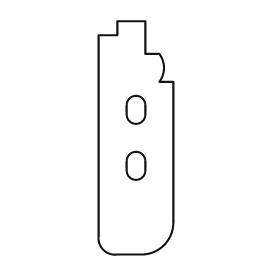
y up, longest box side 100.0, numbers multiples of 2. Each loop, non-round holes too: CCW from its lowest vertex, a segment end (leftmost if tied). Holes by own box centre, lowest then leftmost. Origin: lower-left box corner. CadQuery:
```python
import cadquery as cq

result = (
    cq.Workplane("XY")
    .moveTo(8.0, 0.0)
    .lineTo(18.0, 0.0)
    .threePointArc((28.0, 4.0), (32.0, 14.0))
    .lineTo(32.0, 74.0)
    .lineTo(26.0, 74.0)
    .threePointArc((28.0, 80.0), (26.0, 86.0))
    .lineTo(20.0, 86.0)
    .lineTo(20.0, 100.0)
    .lineTo(8.0, 100.0)
    .lineTo(8.0, 94.0)
    .lineTo(0.0, 94.0)
    .lineTo(0.0, 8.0)
    .threePointArc((2.0, 2.0), (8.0, 0.0))
    .close()
    .moveTo(12.0, 36.0)
    .threePointArc((16.0, 32.0), (20.0, 36.0))
    .lineTo(20.0, 40.0)
    .threePointArc((16.0, 44.0), (12.0, 40.0))
    .close()
    .moveTo(12.0, 60.0)
    .threePointArc((16.0, 56.0), (20.0, 60.0))
    .lineTo(20.0, 64.0)
    .threePointArc((16.0, 68.0), (12.0, 64.0))
    .close()
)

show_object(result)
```